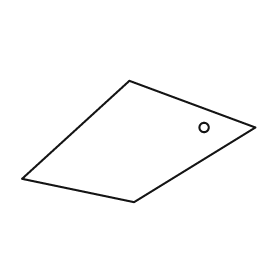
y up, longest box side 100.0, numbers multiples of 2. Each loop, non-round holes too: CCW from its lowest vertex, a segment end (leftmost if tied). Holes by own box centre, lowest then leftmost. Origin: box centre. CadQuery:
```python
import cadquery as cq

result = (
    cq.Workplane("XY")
    .moveTo(-2.0, -26.0)
    .lineTo(50.0, 6.0)
    .lineTo(-4.0, 26.0)
    .lineTo(-50.0, -16.0)
    .close()
    .moveTo(28.0, 6.0)
    .circle(2.0)
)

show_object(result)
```